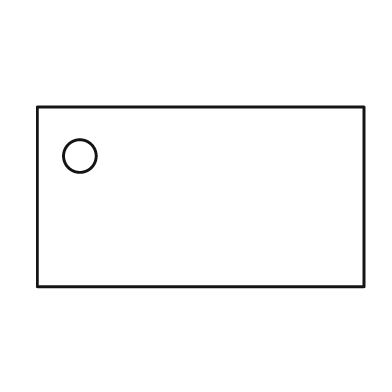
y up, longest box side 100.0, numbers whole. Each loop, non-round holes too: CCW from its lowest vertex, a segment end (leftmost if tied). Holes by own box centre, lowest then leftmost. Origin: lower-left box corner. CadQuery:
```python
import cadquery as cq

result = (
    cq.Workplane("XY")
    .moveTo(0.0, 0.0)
    .lineTo(100.0, 0.0)
    .lineTo(100.0, 55.0)
    .lineTo(0.0, 55.0)
    .close()
    .moveTo(13.0, 40.0)
    .circle(5.0)
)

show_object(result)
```